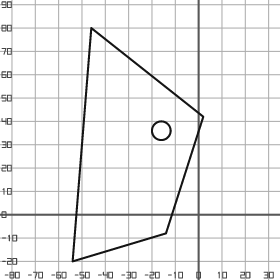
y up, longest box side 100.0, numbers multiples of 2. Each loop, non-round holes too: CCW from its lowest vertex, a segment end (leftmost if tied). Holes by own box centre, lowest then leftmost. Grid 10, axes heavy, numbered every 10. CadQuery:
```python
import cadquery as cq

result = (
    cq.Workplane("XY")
    .moveTo(-54.0, -20.0)
    .lineTo(-14.0, -8.0)
    .lineTo(2.0, 42.0)
    .lineTo(-46.0, 80.0)
    .close()
    .moveTo(-16.0, 36.0)
    .circle(4.0)
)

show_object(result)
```